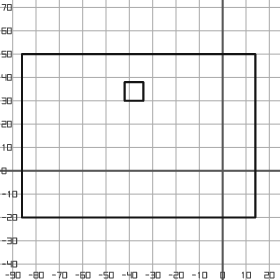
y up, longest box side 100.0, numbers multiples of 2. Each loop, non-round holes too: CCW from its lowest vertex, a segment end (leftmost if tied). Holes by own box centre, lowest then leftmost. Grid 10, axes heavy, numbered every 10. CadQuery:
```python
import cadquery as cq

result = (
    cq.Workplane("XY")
    .moveTo(-86.0, -20.0)
    .lineTo(14.0, -20.0)
    .lineTo(14.0, 50.0)
    .lineTo(-86.0, 50.0)
    .close()
    .moveTo(-42.0, 30.0)
    .lineTo(-34.0, 30.0)
    .lineTo(-34.0, 38.0)
    .lineTo(-42.0, 38.0)
    .close()
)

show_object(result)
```